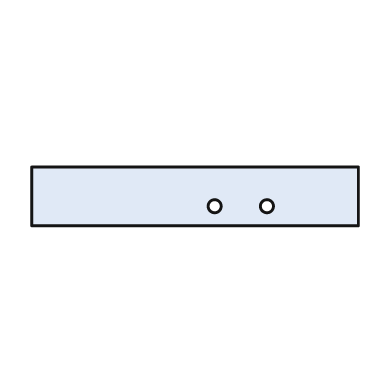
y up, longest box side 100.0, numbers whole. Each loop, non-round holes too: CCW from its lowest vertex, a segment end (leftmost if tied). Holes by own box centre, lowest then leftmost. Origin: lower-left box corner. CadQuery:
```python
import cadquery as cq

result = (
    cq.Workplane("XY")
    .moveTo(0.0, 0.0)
    .lineTo(100.0, 0.0)
    .lineTo(100.0, 18.0)
    .lineTo(0.0, 18.0)
    .close()
    .moveTo(56.0, 6.0)
    .circle(2.0)
    .moveTo(72.0, 6.0)
    .circle(2.0)
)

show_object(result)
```